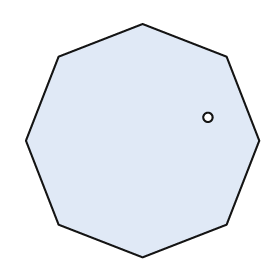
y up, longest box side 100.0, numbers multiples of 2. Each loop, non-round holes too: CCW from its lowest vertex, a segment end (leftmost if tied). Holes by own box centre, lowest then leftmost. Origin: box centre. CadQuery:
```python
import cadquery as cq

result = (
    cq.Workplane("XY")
    .moveTo(0.0, -50.0)
    .lineTo(36.0, -36.0)
    .lineTo(50.0, 0.0)
    .lineTo(36.0, 36.0)
    .lineTo(0.0, 50.0)
    .lineTo(-36.0, 36.0)
    .lineTo(-50.0, 0.0)
    .lineTo(-36.0, -36.0)
    .close()
    .moveTo(28.0, 10.0)
    .circle(2.0)
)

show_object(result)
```